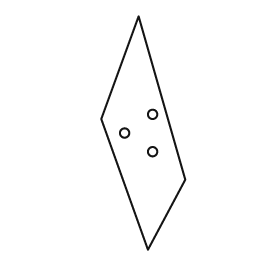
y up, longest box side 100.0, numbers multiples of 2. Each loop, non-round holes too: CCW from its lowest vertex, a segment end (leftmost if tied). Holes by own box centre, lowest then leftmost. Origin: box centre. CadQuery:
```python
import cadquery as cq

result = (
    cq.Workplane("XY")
    .moveTo(2.0, -50.0)
    .lineTo(18.0, -20.0)
    .lineTo(-2.0, 50.0)
    .lineTo(-18.0, 6.0)
    .close()
    .moveTo(4.0, -8.0)
    .circle(2.0)
    .moveTo(-8.0, 0.0)
    .circle(2.0)
    .moveTo(4.0, 8.0)
    .circle(2.0)
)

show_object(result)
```